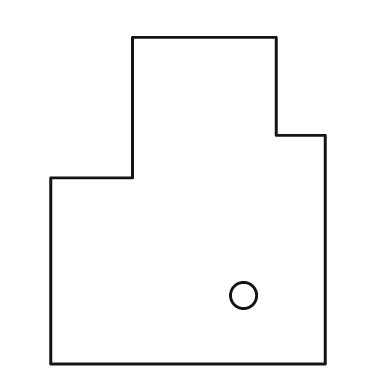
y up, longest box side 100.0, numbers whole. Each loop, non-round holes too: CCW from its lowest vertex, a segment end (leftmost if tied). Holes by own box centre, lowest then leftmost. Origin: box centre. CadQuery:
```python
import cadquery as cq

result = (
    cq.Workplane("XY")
    .moveTo(-42.0, -50.0)
    .lineTo(42.0, -50.0)
    .lineTo(42.0, 20.0)
    .lineTo(27.0, 20.0)
    .lineTo(27.0, 50.0)
    .lineTo(-17.0, 50.0)
    .lineTo(-17.0, 7.0)
    .lineTo(-42.0, 7.0)
    .close()
    .moveTo(17.0, -29.0)
    .circle(4.0)
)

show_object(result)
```